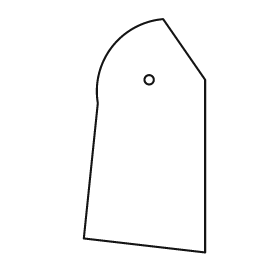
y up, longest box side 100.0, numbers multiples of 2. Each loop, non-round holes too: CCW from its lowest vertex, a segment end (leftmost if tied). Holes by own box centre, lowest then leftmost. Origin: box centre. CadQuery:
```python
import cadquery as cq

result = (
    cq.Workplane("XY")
    .moveTo(26.0, -50.0)
    .lineTo(26.0, 24.0)
    .lineTo(8.0, 50.0)
    .threePointArc((-14.0, 38.0), (-20.0, 14.0))
    .lineTo(-26.0, -44.0)
    .close()
    .moveTo(2.0, 24.0)
    .circle(2.0)
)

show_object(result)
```